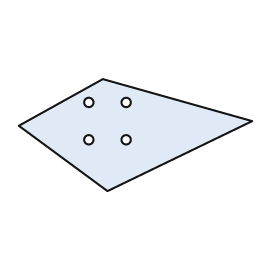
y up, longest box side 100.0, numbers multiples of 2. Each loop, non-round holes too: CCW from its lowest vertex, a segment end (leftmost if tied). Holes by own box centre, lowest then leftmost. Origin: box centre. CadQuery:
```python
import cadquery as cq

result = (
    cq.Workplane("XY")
    .moveTo(-12.0, -24.0)
    .lineTo(50.0, 6.0)
    .lineTo(-14.0, 24.0)
    .lineTo(-50.0, 4.0)
    .close()
    .moveTo(-20.0, -2.0)
    .circle(2.0)
    .moveTo(-4.0, -2.0)
    .circle(2.0)
    .moveTo(-20.0, 14.0)
    .circle(2.0)
    .moveTo(-4.0, 14.0)
    .circle(2.0)
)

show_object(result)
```